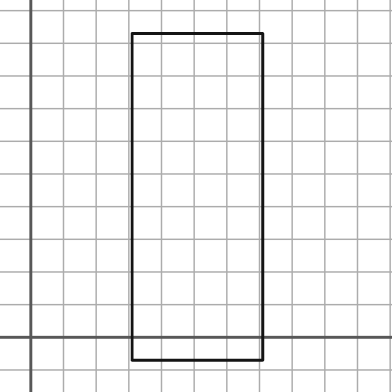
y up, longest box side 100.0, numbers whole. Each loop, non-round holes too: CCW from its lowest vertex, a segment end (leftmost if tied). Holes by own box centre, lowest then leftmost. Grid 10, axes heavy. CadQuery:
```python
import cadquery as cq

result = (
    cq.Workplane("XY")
    .moveTo(31.0, -7.0)
    .lineTo(71.0, -7.0)
    .lineTo(71.0, 93.0)
    .lineTo(31.0, 93.0)
    .close()
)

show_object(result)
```